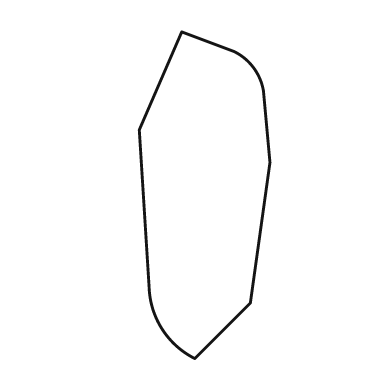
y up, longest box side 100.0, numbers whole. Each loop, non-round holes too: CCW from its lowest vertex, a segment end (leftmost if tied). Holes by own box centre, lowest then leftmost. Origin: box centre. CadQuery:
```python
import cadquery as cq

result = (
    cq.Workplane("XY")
    .moveTo(-3.0, -50.0)
    .lineTo(14.0, -33.0)
    .lineTo(20.0, 10.0)
    .lineTo(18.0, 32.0)
    .threePointArc((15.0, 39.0), (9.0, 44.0))
    .lineTo(-7.0, 50.0)
    .lineTo(-20.0, 20.0)
    .lineTo(-17.0, -28.0)
    .threePointArc((-13.0, -41.0), (-3.0, -50.0))
    .close()
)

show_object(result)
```